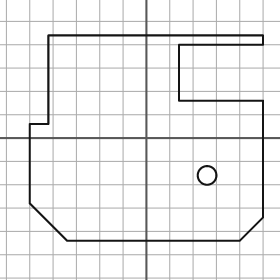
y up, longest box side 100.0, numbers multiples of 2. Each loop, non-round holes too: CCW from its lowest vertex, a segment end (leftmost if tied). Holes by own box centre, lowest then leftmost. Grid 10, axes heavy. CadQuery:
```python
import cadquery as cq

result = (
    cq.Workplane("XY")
    .moveTo(-34.0, -44.0)
    .lineTo(40.0, -44.0)
    .lineTo(50.0, -34.0)
    .lineTo(50.0, 16.0)
    .lineTo(14.0, 16.0)
    .lineTo(14.0, 40.0)
    .lineTo(50.0, 40.0)
    .lineTo(50.0, 44.0)
    .lineTo(-42.0, 44.0)
    .lineTo(-42.0, 6.0)
    .lineTo(-50.0, 6.0)
    .lineTo(-50.0, -28.0)
    .close()
    .moveTo(26.0, -16.0)
    .circle(4.0)
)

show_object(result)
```